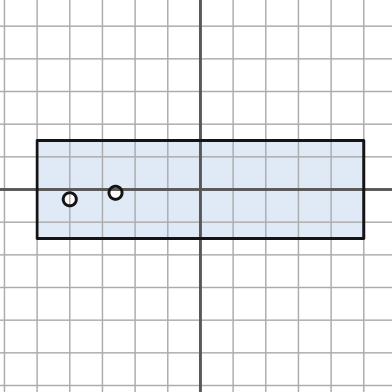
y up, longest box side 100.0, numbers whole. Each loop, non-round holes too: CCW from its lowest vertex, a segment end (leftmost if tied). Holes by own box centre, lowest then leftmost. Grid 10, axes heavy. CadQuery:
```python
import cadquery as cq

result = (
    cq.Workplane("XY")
    .moveTo(-50.0, -15.0)
    .lineTo(50.0, -15.0)
    .lineTo(50.0, 15.0)
    .lineTo(-50.0, 15.0)
    .close()
    .moveTo(-40.0, -3.0)
    .circle(2.0)
    .moveTo(-26.0, -1.0)
    .circle(2.0)
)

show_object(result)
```